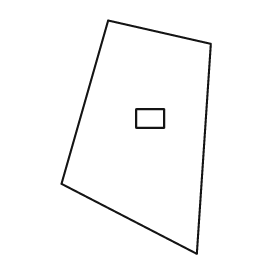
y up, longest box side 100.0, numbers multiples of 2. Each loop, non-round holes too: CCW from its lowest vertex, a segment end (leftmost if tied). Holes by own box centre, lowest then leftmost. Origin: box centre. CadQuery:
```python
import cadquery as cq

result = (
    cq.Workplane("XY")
    .moveTo(26.0, -50.0)
    .lineTo(32.0, 40.0)
    .lineTo(-12.0, 50.0)
    .lineTo(-32.0, -20.0)
    .close()
    .moveTo(0.0, 4.0)
    .lineTo(12.0, 4.0)
    .lineTo(12.0, 12.0)
    .lineTo(0.0, 12.0)
    .close()
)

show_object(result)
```